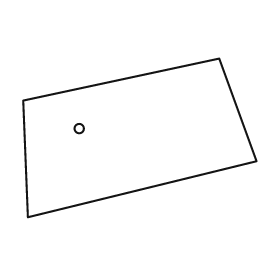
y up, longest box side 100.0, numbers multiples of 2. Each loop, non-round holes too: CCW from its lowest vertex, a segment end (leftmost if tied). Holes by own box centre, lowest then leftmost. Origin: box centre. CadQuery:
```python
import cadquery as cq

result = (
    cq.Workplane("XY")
    .moveTo(-48.0, -34.0)
    .lineTo(50.0, -10.0)
    .lineTo(34.0, 34.0)
    .lineTo(-50.0, 16.0)
    .close()
    .moveTo(-26.0, 4.0)
    .circle(2.0)
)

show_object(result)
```